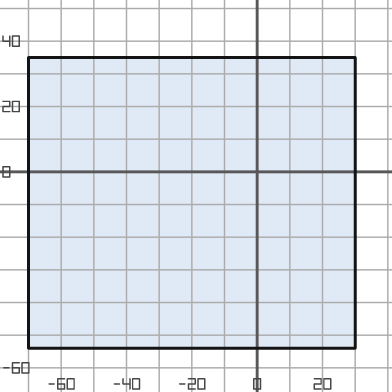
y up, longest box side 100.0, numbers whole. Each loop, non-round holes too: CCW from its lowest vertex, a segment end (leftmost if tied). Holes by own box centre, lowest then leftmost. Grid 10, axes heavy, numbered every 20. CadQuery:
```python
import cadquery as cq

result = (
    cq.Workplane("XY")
    .moveTo(-70.0, -54.0)
    .lineTo(30.0, -54.0)
    .lineTo(30.0, 35.0)
    .lineTo(-70.0, 35.0)
    .close()
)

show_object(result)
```